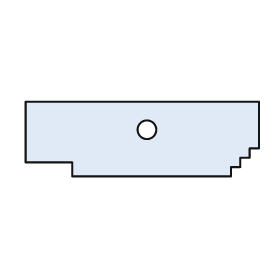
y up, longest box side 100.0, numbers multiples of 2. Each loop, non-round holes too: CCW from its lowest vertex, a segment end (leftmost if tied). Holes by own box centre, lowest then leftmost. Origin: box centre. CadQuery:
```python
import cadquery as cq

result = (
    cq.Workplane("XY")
    .moveTo(-30.0, -16.0)
    .lineTo(38.0, -16.0)
    .lineTo(38.0, -12.0)
    .lineTo(42.0, -12.0)
    .lineTo(42.0, -8.0)
    .lineTo(46.0, -8.0)
    .lineTo(46.0, -4.0)
    .lineTo(50.0, -4.0)
    .lineTo(50.0, 16.0)
    .lineTo(-50.0, 16.0)
    .lineTo(-50.0, -10.0)
    .lineTo(-30.0, -10.0)
    .close()
    .moveTo(2.0, 4.0)
    .circle(4.0)
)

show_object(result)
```